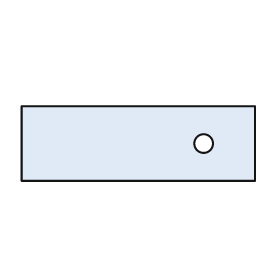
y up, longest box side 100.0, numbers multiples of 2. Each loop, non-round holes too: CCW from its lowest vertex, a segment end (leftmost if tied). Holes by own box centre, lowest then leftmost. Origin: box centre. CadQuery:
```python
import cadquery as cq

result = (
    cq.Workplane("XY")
    .moveTo(-50.0, -16.0)
    .lineTo(50.0, -16.0)
    .lineTo(50.0, 16.0)
    .lineTo(-50.0, 16.0)
    .close()
    .moveTo(28.0, 0.0)
    .circle(4.0)
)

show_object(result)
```